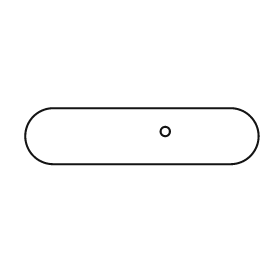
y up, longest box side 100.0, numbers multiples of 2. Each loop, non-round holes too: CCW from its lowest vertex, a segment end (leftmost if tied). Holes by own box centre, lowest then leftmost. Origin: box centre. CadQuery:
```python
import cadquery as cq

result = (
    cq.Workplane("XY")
    .moveTo(-38.0, -12.0)
    .lineTo(38.0, -12.0)
    .threePointArc((50.0, 0.0), (38.0, 12.0))
    .lineTo(-38.0, 12.0)
    .threePointArc((-50.0, 0.0), (-38.0, -12.0))
    .close()
    .moveTo(10.0, 2.0)
    .circle(2.0)
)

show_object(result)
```